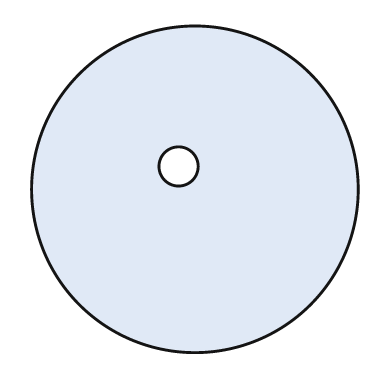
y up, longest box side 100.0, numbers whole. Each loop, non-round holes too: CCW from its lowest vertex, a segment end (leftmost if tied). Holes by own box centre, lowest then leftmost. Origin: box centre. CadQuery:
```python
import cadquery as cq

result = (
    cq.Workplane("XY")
    .moveTo(0.0, 0.0)
    .circle(50.0)
    .moveTo(-5.0, 7.0)
    .circle(6.0)
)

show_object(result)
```